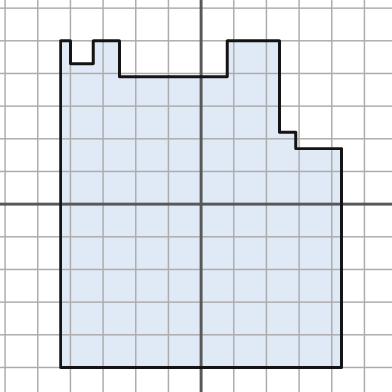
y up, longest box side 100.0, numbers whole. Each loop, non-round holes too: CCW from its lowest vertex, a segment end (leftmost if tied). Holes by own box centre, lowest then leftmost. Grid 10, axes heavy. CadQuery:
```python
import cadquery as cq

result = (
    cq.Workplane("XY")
    .moveTo(-43.0, -50.0)
    .lineTo(43.0, -50.0)
    .lineTo(43.0, 17.0)
    .lineTo(29.0, 17.0)
    .lineTo(29.0, 22.0)
    .lineTo(24.0, 22.0)
    .lineTo(24.0, 50.0)
    .lineTo(8.0, 50.0)
    .lineTo(8.0, 39.0)
    .lineTo(-25.0, 39.0)
    .lineTo(-25.0, 50.0)
    .lineTo(-33.0, 50.0)
    .lineTo(-33.0, 43.0)
    .lineTo(-40.0, 43.0)
    .lineTo(-40.0, 50.0)
    .lineTo(-43.0, 50.0)
    .close()
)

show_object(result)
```